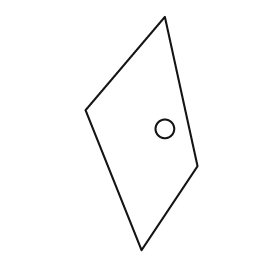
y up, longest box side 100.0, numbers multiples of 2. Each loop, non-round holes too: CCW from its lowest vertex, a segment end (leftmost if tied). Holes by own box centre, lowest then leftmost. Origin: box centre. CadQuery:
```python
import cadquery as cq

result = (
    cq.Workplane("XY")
    .moveTo(0.0, -50.0)
    .lineTo(24.0, -14.0)
    .lineTo(10.0, 50.0)
    .lineTo(-24.0, 10.0)
    .close()
    .moveTo(10.0, 2.0)
    .circle(4.0)
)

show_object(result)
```